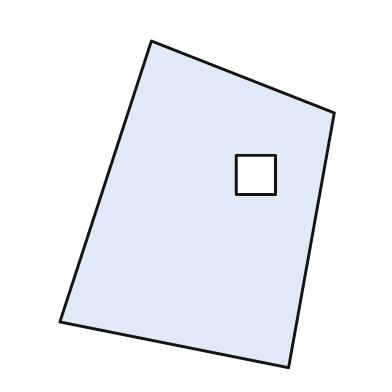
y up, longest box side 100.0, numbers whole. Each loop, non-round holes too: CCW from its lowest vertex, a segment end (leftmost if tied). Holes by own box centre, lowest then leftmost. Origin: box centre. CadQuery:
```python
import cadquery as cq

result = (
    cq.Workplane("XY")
    .moveTo(28.0, -50.0)
    .lineTo(42.0, 28.0)
    .lineTo(-14.0, 50.0)
    .lineTo(-42.0, -36.0)
    .close()
    .moveTo(12.0, 3.0)
    .lineTo(24.0, 3.0)
    .lineTo(24.0, 15.0)
    .lineTo(12.0, 15.0)
    .close()
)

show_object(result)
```